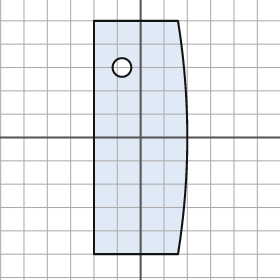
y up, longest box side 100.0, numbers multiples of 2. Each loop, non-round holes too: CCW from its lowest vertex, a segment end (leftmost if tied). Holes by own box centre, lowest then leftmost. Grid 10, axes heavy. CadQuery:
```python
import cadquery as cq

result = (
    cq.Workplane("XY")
    .moveTo(-20.0, -50.0)
    .lineTo(16.0, -50.0)
    .threePointArc((20.0, 0.0), (16.0, 50.0))
    .lineTo(-20.0, 50.0)
    .close()
    .moveTo(-8.0, 30.0)
    .circle(4.0)
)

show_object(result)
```